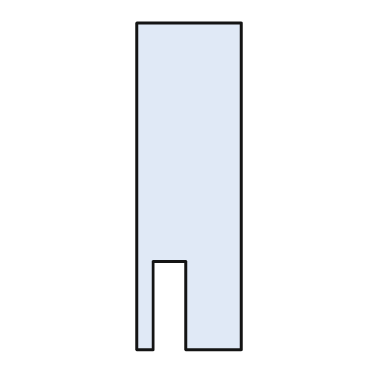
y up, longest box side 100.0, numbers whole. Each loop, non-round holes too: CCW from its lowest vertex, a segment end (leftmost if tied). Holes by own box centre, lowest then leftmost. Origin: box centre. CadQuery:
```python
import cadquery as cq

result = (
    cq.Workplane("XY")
    .moveTo(-16.0, -50.0)
    .lineTo(-11.0, -50.0)
    .lineTo(-11.0, -23.0)
    .lineTo(-1.0, -23.0)
    .lineTo(-1.0, -50.0)
    .lineTo(16.0, -50.0)
    .lineTo(16.0, 50.0)
    .lineTo(-16.0, 50.0)
    .close()
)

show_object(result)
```